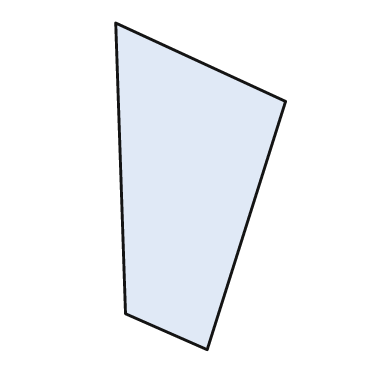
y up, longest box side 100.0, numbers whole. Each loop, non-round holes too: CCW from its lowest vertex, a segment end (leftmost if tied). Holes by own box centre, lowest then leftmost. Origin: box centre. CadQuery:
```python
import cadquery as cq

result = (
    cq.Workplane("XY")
    .moveTo(2.0, -50.0)
    .lineTo(26.0, 26.0)
    .lineTo(-26.0, 50.0)
    .lineTo(-23.0, -39.0)
    .close()
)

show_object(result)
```